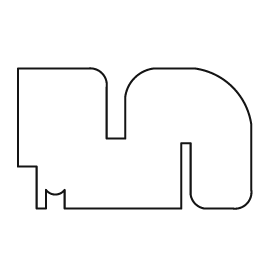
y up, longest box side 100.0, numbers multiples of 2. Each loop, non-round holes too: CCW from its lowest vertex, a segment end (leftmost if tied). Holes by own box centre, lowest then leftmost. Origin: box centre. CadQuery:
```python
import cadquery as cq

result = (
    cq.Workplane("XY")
    .moveTo(-42.0, -30.0)
    .lineTo(-38.0, -30.0)
    .lineTo(-38.0, -22.0)
    .threePointArc((-34.0, -24.0), (-30.0, -22.0))
    .lineTo(-30.0, -30.0)
    .lineTo(20.0, -30.0)
    .lineTo(20.0, -2.0)
    .lineTo(24.0, -2.0)
    .lineTo(24.0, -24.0)
    .threePointArc((26.0, -28.0), (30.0, -30.0))
    .lineTo(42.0, -30.0)
    .threePointArc((48.0, -28.0), (50.0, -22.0))
    .lineTo(50.0, 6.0)
    .threePointArc((42.0, 22.0), (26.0, 30.0))
    .lineTo(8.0, 30.0)
    .threePointArc((0.0, 26.0), (-4.0, 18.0))
    .lineTo(-4.0, 0.0)
    .lineTo(-12.0, 0.0)
    .lineTo(-12.0, 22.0)
    .threePointArc((-14.0, 28.0), (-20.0, 30.0))
    .lineTo(-50.0, 30.0)
    .lineTo(-50.0, -12.0)
    .lineTo(-42.0, -12.0)
    .close()
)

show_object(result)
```